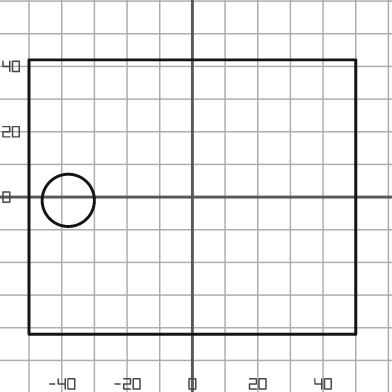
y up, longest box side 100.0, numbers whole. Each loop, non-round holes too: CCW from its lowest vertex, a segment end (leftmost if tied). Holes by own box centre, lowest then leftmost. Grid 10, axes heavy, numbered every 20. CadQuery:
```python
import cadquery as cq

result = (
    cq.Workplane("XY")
    .moveTo(-50.0, -42.0)
    .lineTo(50.0, -42.0)
    .lineTo(50.0, 42.0)
    .lineTo(-50.0, 42.0)
    .close()
    .moveTo(-38.0, -1.0)
    .circle(8.0)
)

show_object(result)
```